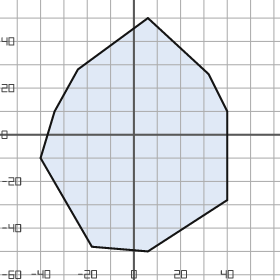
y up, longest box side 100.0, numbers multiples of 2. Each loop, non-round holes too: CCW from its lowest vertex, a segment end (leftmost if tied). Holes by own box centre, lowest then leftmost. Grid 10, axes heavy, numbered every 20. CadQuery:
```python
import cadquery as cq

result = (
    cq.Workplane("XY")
    .moveTo(6.0, -50.0)
    .lineTo(40.0, -28.0)
    .lineTo(40.0, 10.0)
    .lineTo(32.0, 26.0)
    .lineTo(6.0, 50.0)
    .lineTo(-24.0, 28.0)
    .lineTo(-34.0, 10.0)
    .lineTo(-40.0, -10.0)
    .lineTo(-18.0, -48.0)
    .close()
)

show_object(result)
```